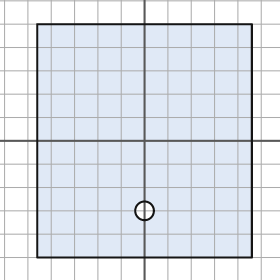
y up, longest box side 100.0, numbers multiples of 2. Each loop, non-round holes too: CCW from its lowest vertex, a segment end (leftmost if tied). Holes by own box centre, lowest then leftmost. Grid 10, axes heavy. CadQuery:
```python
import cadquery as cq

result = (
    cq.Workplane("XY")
    .moveTo(-46.0, -50.0)
    .lineTo(46.0, -50.0)
    .lineTo(46.0, 50.0)
    .lineTo(-46.0, 50.0)
    .close()
    .moveTo(0.0, -30.0)
    .circle(4.0)
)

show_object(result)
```